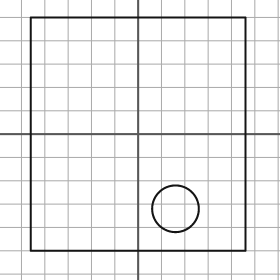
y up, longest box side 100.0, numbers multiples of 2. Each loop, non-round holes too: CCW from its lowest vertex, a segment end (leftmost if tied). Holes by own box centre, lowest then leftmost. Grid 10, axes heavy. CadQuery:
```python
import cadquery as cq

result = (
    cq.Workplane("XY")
    .moveTo(-46.0, -50.0)
    .lineTo(46.0, -50.0)
    .lineTo(46.0, 50.0)
    .lineTo(-46.0, 50.0)
    .close()
    .moveTo(16.0, -32.0)
    .circle(10.0)
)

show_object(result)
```